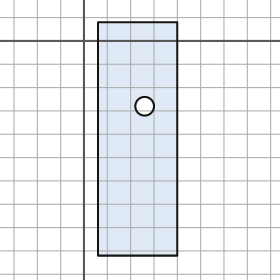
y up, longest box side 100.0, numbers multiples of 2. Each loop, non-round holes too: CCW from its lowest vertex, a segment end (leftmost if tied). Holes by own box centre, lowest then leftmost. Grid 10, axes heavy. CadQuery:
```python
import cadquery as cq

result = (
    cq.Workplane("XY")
    .moveTo(6.0, -92.0)
    .lineTo(40.0, -92.0)
    .lineTo(40.0, 8.0)
    .lineTo(6.0, 8.0)
    .close()
    .moveTo(26.0, -28.0)
    .circle(4.0)
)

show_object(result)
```